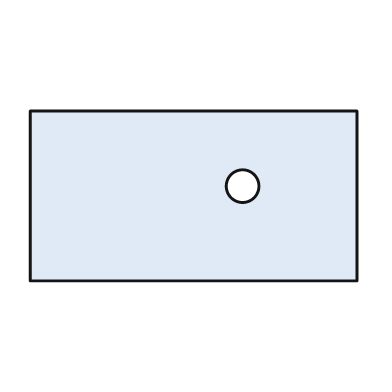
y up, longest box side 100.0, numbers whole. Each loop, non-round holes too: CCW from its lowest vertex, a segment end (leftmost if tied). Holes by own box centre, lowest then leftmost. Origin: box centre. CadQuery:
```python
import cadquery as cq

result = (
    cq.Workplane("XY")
    .moveTo(-50.0, -26.0)
    .lineTo(50.0, -26.0)
    .lineTo(50.0, 26.0)
    .lineTo(-50.0, 26.0)
    .close()
    .moveTo(15.0, 3.0)
    .circle(5.0)
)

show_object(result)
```